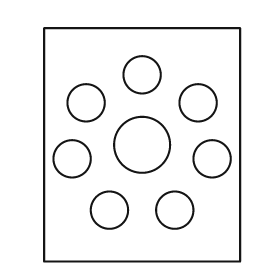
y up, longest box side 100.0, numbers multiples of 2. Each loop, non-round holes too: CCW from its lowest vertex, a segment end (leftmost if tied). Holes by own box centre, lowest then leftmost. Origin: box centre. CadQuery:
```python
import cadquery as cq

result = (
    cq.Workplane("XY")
    .moveTo(-42.0, -50.0)
    .lineTo(42.0, -50.0)
    .lineTo(42.0, 50.0)
    .lineTo(-42.0, 50.0)
    .close()
    .moveTo(-14.0, -28.0)
    .circle(8.0)
    .moveTo(14.0, -28.0)
    .circle(8.0)
    .moveTo(-30.0, -6.0)
    .circle(8.0)
    .moveTo(30.0, -6.0)
    .circle(8.0)
    .moveTo(0.0, 0.0)
    .circle(12.0)
    .moveTo(-24.0, 18.0)
    .circle(8.0)
    .moveTo(24.0, 18.0)
    .circle(8.0)
    .moveTo(0.0, 30.0)
    .circle(8.0)
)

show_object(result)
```